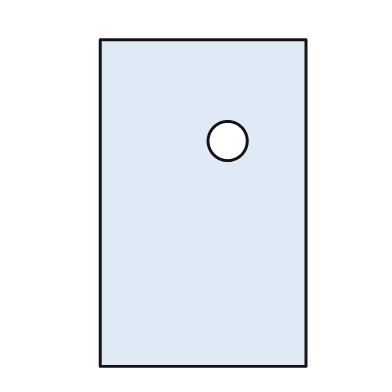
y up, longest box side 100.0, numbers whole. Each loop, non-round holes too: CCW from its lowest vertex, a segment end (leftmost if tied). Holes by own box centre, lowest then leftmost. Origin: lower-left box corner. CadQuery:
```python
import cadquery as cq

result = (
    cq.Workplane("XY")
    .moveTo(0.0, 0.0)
    .lineTo(63.0, 0.0)
    .lineTo(63.0, 100.0)
    .lineTo(0.0, 100.0)
    .close()
    .moveTo(39.0, 69.0)
    .circle(6.0)
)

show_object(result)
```